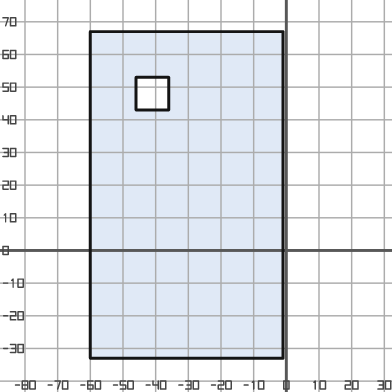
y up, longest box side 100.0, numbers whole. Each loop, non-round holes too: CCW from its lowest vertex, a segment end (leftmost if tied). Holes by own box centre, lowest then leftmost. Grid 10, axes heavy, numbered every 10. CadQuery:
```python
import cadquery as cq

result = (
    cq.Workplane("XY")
    .moveTo(-60.0, -33.0)
    .lineTo(-1.0, -33.0)
    .lineTo(-1.0, 67.0)
    .lineTo(-60.0, 67.0)
    .close()
    .moveTo(-46.0, 43.0)
    .lineTo(-36.0, 43.0)
    .lineTo(-36.0, 53.0)
    .lineTo(-46.0, 53.0)
    .close()
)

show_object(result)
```